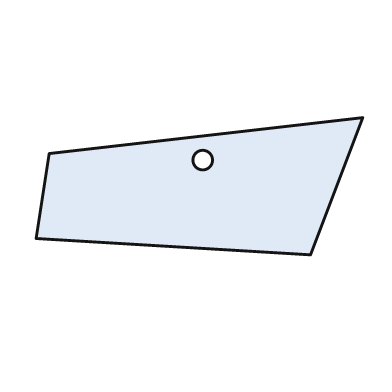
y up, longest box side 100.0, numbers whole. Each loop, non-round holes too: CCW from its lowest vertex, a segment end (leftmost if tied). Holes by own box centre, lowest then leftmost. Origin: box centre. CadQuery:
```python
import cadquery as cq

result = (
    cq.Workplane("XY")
    .moveTo(34.0, -21.0)
    .lineTo(50.0, 21.0)
    .lineTo(-46.0, 10.0)
    .lineTo(-50.0, -16.0)
    .close()
    .moveTo(1.0, 8.0)
    .circle(3.0)
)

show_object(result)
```